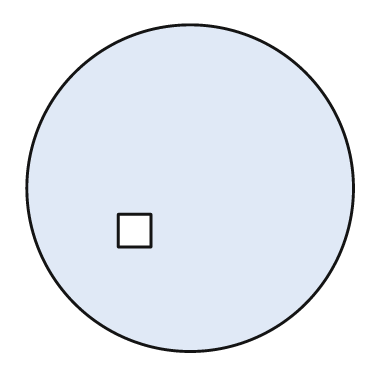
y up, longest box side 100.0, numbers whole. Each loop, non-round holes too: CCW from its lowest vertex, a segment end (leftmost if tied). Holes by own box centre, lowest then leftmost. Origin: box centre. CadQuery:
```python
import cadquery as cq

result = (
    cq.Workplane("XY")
    .moveTo(0.0, 0.0)
    .circle(50.0)
    .moveTo(-22.0, -18.0)
    .lineTo(-12.0, -18.0)
    .lineTo(-12.0, -8.0)
    .lineTo(-22.0, -8.0)
    .close()
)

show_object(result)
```